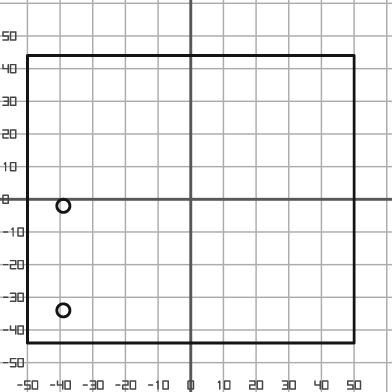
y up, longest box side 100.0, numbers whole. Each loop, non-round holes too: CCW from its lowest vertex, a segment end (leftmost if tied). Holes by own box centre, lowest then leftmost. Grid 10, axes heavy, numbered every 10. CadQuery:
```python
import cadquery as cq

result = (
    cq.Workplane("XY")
    .moveTo(-50.0, -44.0)
    .lineTo(50.0, -44.0)
    .lineTo(50.0, 44.0)
    .lineTo(-50.0, 44.0)
    .close()
    .moveTo(-39.0, -34.0)
    .circle(2.0)
    .moveTo(-39.0, -2.0)
    .circle(2.0)
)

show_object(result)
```